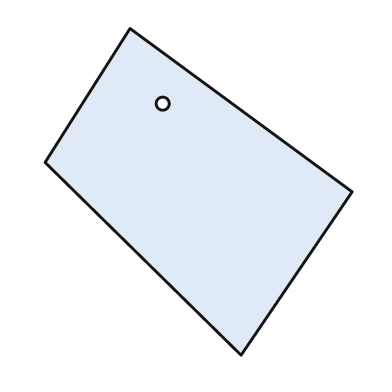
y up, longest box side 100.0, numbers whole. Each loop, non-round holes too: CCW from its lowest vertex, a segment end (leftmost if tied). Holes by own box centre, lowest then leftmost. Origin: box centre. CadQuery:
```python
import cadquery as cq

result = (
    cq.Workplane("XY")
    .moveTo(13.0, -50.0)
    .lineTo(47.0, 0.0)
    .lineTo(-21.0, 50.0)
    .lineTo(-47.0, 9.0)
    .close()
    .moveTo(-11.0, 27.0)
    .circle(2.0)
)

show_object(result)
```